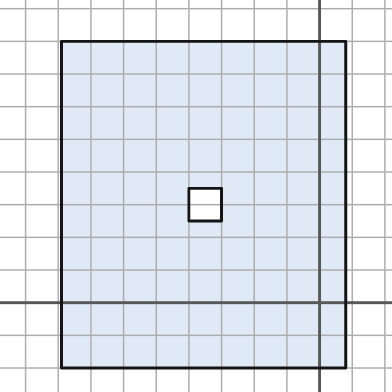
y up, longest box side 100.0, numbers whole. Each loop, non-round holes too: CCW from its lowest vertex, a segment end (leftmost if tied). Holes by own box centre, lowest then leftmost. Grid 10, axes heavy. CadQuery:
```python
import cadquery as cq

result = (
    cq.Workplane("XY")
    .moveTo(-79.0, -20.0)
    .lineTo(8.0, -20.0)
    .lineTo(8.0, 80.0)
    .lineTo(-79.0, 80.0)
    .close()
    .moveTo(-40.0, 25.0)
    .lineTo(-30.0, 25.0)
    .lineTo(-30.0, 35.0)
    .lineTo(-40.0, 35.0)
    .close()
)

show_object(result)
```